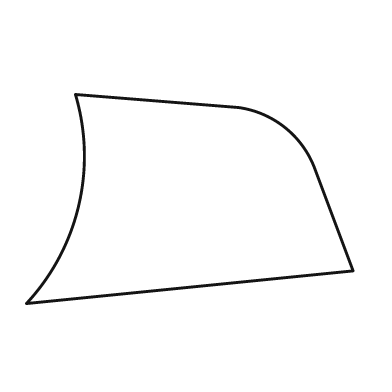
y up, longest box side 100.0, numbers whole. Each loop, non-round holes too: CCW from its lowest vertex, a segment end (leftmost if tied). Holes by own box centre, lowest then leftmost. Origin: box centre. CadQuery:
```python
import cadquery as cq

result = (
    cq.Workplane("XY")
    .moveTo(-50.0, -32.0)
    .lineTo(50.0, -22.0)
    .lineTo(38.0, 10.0)
    .threePointArc((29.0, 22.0), (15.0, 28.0))
    .lineTo(-35.0, 32.0)
    .threePointArc((-34.0, -2.0), (-50.0, -32.0))
    .close()
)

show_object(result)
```